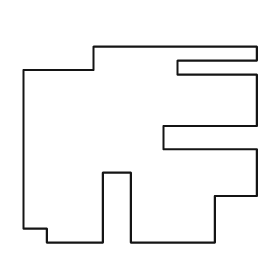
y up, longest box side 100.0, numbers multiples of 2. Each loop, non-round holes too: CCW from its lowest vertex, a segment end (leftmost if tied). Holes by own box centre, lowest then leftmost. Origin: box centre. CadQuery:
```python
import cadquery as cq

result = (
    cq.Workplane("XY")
    .moveTo(-40.0, -42.0)
    .lineTo(-16.0, -42.0)
    .lineTo(-16.0, -12.0)
    .lineTo(-4.0, -12.0)
    .lineTo(-4.0, -42.0)
    .lineTo(32.0, -42.0)
    .lineTo(32.0, -22.0)
    .lineTo(50.0, -22.0)
    .lineTo(50.0, -2.0)
    .lineTo(10.0, -2.0)
    .lineTo(10.0, 8.0)
    .lineTo(50.0, 8.0)
    .lineTo(50.0, 30.0)
    .lineTo(16.0, 30.0)
    .lineTo(16.0, 36.0)
    .lineTo(50.0, 36.0)
    .lineTo(50.0, 42.0)
    .lineTo(-20.0, 42.0)
    .lineTo(-20.0, 32.0)
    .lineTo(-50.0, 32.0)
    .lineTo(-50.0, -36.0)
    .lineTo(-40.0, -36.0)
    .close()
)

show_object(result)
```